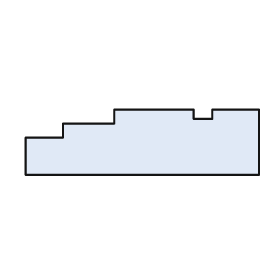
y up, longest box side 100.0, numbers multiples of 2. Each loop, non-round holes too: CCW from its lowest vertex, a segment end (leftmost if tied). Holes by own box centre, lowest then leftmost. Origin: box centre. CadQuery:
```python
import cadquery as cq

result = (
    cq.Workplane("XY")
    .moveTo(-50.0, -14.0)
    .lineTo(50.0, -14.0)
    .lineTo(50.0, 14.0)
    .lineTo(30.0, 14.0)
    .lineTo(30.0, 10.0)
    .lineTo(22.0, 10.0)
    .lineTo(22.0, 14.0)
    .lineTo(-12.0, 14.0)
    .lineTo(-12.0, 8.0)
    .lineTo(-34.0, 8.0)
    .lineTo(-34.0, 2.0)
    .lineTo(-50.0, 2.0)
    .close()
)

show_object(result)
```